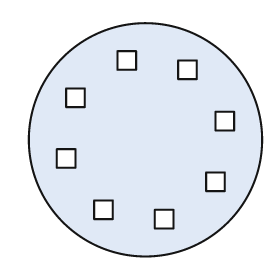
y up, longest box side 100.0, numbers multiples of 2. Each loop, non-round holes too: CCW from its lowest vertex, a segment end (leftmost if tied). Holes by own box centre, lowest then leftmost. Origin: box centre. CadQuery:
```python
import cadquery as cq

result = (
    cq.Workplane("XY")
    .moveTo(0.0, 0.0)
    .circle(50.0)
    .moveTo(4.0, -38.0)
    .lineTo(12.0, -38.0)
    .lineTo(12.0, -30.0)
    .lineTo(4.0, -30.0)
    .close()
    .moveTo(-22.0, -34.0)
    .lineTo(-14.0, -34.0)
    .lineTo(-14.0, -26.0)
    .lineTo(-22.0, -26.0)
    .close()
    .moveTo(26.0, -22.0)
    .lineTo(34.0, -22.0)
    .lineTo(34.0, -14.0)
    .lineTo(26.0, -14.0)
    .close()
    .moveTo(-38.0, -12.0)
    .lineTo(-30.0, -12.0)
    .lineTo(-30.0, -4.0)
    .lineTo(-38.0, -4.0)
    .close()
    .moveTo(30.0, 4.0)
    .lineTo(38.0, 4.0)
    .lineTo(38.0, 12.0)
    .lineTo(30.0, 12.0)
    .close()
    .moveTo(-34.0, 14.0)
    .lineTo(-26.0, 14.0)
    .lineTo(-26.0, 22.0)
    .lineTo(-34.0, 22.0)
    .close()
    .moveTo(14.0, 26.0)
    .lineTo(22.0, 26.0)
    .lineTo(22.0, 34.0)
    .lineTo(14.0, 34.0)
    .close()
    .moveTo(-12.0, 30.0)
    .lineTo(-4.0, 30.0)
    .lineTo(-4.0, 38.0)
    .lineTo(-12.0, 38.0)
    .close()
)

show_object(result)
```